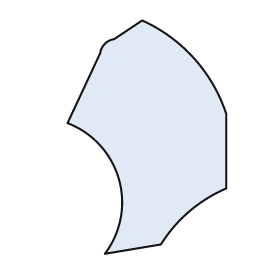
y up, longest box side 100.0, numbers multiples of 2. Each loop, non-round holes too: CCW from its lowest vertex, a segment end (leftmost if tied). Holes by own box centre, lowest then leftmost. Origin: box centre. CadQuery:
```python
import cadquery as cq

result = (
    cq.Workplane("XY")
    .moveTo(-18.0, -50.0)
    .lineTo(6.0, -46.0)
    .threePointArc((18.0, -32.0), (34.0, -22.0))
    .lineTo(34.0, 10.0)
    .threePointArc((20.0, 34.0), (-2.0, 50.0))
    .lineTo(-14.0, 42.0)
    .threePointArc((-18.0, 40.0), (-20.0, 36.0))
    .lineTo(-34.0, 6.0)
    .threePointArc((-12.0, -18.0), (-18.0, -50.0))
    .close()
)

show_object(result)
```